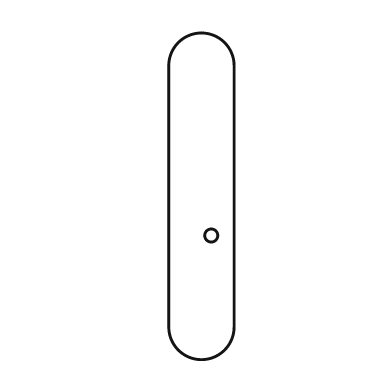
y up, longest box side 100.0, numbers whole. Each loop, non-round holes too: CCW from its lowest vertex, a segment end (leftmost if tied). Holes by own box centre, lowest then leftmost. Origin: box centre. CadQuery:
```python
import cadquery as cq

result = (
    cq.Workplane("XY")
    .moveTo(-10.0, -40.0)
    .threePointArc((0.0, -50.0), (10.0, -40.0))
    .lineTo(10.0, 40.0)
    .threePointArc((0.0, 50.0), (-10.0, 40.0))
    .close()
    .moveTo(3.0, -12.0)
    .circle(2.0)
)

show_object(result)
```